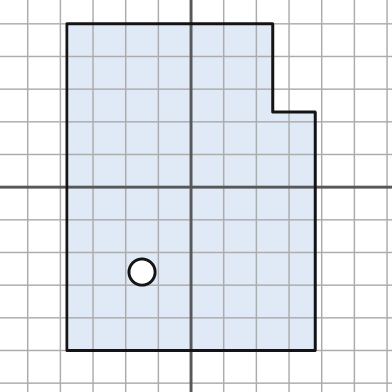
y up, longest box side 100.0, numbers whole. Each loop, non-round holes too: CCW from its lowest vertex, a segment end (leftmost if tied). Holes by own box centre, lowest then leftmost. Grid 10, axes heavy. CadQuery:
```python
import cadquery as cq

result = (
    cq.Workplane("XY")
    .moveTo(-38.0, -50.0)
    .lineTo(38.0, -50.0)
    .lineTo(38.0, 23.0)
    .lineTo(25.0, 23.0)
    .lineTo(25.0, 50.0)
    .lineTo(-38.0, 50.0)
    .close()
    .moveTo(-15.0, -26.0)
    .circle(4.0)
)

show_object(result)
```